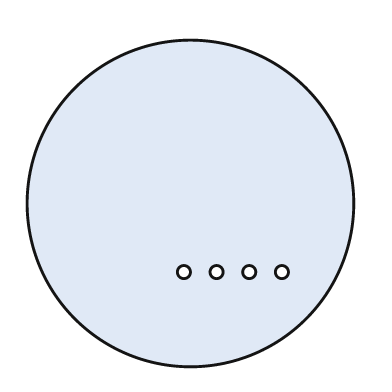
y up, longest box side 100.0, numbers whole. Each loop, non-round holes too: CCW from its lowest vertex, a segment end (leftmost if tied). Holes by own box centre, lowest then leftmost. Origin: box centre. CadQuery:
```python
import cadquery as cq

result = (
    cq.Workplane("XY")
    .moveTo(0.0, 0.0)
    .circle(50.0)
    .moveTo(-2.0, -21.0)
    .circle(2.0)
    .moveTo(8.0, -21.0)
    .circle(2.0)
    .moveTo(18.0, -21.0)
    .circle(2.0)
    .moveTo(28.0, -21.0)
    .circle(2.0)
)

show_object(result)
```